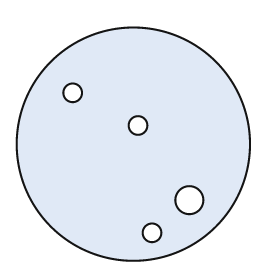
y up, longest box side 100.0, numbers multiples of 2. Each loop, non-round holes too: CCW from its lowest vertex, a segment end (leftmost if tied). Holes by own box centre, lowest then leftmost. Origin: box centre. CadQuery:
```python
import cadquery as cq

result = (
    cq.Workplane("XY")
    .moveTo(0.0, 0.0)
    .circle(50.0)
    .moveTo(8.0, -38.0)
    .circle(4.0)
    .moveTo(24.0, -24.0)
    .circle(6.0)
    .moveTo(2.0, 8.0)
    .circle(4.0)
    .moveTo(-26.0, 22.0)
    .circle(4.0)
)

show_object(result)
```